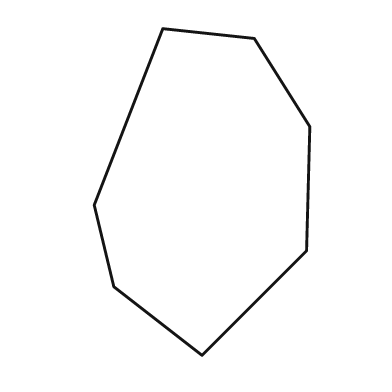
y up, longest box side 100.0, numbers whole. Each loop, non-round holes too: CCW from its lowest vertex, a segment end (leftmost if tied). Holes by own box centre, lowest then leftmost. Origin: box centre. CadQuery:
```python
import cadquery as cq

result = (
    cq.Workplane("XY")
    .moveTo(0.0, -50.0)
    .lineTo(32.0, -18.0)
    .lineTo(33.0, 20.0)
    .lineTo(16.0, 47.0)
    .lineTo(-12.0, 50.0)
    .lineTo(-33.0, -4.0)
    .lineTo(-27.0, -29.0)
    .close()
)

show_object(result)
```